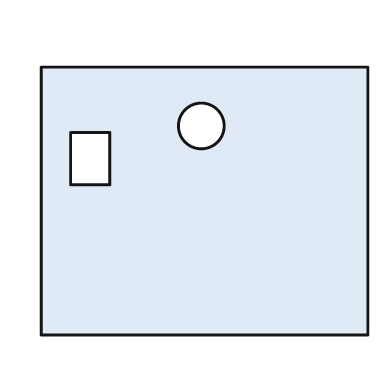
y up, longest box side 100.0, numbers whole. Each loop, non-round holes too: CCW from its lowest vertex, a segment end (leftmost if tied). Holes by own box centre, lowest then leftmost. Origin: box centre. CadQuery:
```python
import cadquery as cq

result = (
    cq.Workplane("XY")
    .moveTo(-50.0, -41.0)
    .lineTo(50.0, -41.0)
    .lineTo(50.0, 41.0)
    .lineTo(-50.0, 41.0)
    .close()
    .moveTo(-41.0, 5.0)
    .lineTo(-29.0, 5.0)
    .lineTo(-29.0, 21.0)
    .lineTo(-41.0, 21.0)
    .close()
    .moveTo(-1.0, 23.0)
    .circle(7.0)
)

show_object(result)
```